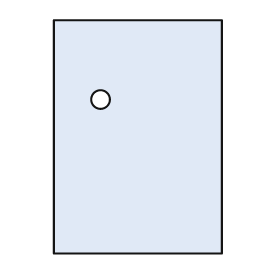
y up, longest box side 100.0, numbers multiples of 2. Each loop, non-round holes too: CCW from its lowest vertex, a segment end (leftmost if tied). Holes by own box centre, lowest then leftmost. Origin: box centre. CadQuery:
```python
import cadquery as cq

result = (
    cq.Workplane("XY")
    .moveTo(-36.0, -50.0)
    .lineTo(36.0, -50.0)
    .lineTo(36.0, 50.0)
    .lineTo(-36.0, 50.0)
    .close()
    .moveTo(-16.0, 16.0)
    .circle(4.0)
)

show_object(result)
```